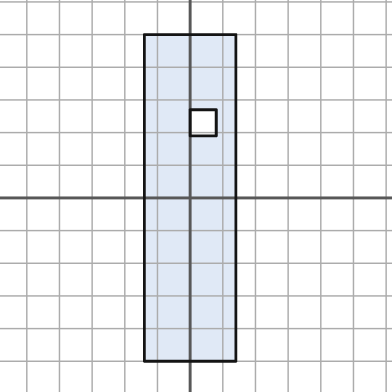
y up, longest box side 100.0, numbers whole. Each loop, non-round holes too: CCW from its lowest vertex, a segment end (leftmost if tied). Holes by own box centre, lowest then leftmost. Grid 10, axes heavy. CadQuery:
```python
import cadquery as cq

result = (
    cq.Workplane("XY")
    .moveTo(-14.0, -50.0)
    .lineTo(14.0, -50.0)
    .lineTo(14.0, 50.0)
    .lineTo(-14.0, 50.0)
    .close()
    .moveTo(0.0, 19.0)
    .lineTo(8.0, 19.0)
    .lineTo(8.0, 27.0)
    .lineTo(0.0, 27.0)
    .close()
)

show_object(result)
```